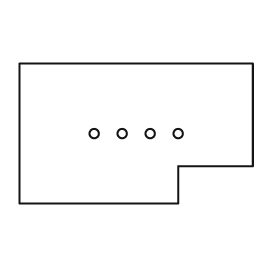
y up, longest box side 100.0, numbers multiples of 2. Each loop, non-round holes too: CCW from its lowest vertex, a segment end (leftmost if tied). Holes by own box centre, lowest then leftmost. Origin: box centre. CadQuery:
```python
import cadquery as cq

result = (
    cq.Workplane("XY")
    .moveTo(-50.0, -30.0)
    .lineTo(18.0, -30.0)
    .lineTo(18.0, -14.0)
    .lineTo(50.0, -14.0)
    .lineTo(50.0, 30.0)
    .lineTo(-50.0, 30.0)
    .close()
    .moveTo(-18.0, 0.0)
    .circle(2.0)
    .moveTo(-6.0, 0.0)
    .circle(2.0)
    .moveTo(6.0, 0.0)
    .circle(2.0)
    .moveTo(18.0, 0.0)
    .circle(2.0)
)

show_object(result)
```